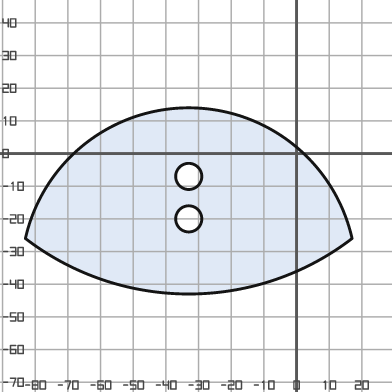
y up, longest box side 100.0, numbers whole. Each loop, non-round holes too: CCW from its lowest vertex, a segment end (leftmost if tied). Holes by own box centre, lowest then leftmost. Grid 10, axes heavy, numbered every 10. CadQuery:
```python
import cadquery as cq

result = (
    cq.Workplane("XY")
    .moveTo(-83.0, -26.0)
    .threePointArc((-33.0, -43.0), (17.0, -26.0))
    .threePointArc((-33.0, 14.0), (-83.0, -26.0))
    .close()
    .moveTo(-33.0, -20.0)
    .circle(4.0)
    .moveTo(-33.0, -7.0)
    .circle(4.0)
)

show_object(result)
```